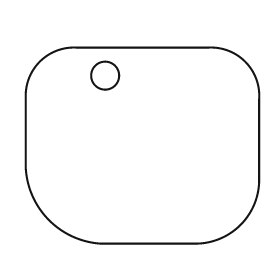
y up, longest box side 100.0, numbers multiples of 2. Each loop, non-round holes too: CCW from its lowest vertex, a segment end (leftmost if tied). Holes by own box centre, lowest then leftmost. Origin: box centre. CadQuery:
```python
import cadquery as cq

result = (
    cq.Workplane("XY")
    .moveTo(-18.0, -42.0)
    .lineTo(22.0, -42.0)
    .threePointArc((42.0, -34.0), (50.0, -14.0))
    .lineTo(50.0, 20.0)
    .threePointArc((44.0, 36.0), (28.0, 42.0))
    .lineTo(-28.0, 42.0)
    .threePointArc((-44.0, 36.0), (-50.0, 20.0))
    .lineTo(-50.0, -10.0)
    .threePointArc((-40.0, -32.0), (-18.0, -42.0))
    .close()
    .moveTo(-16.0, 30.0)
    .circle(6.0)
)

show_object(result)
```